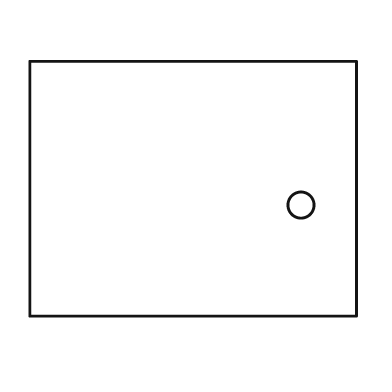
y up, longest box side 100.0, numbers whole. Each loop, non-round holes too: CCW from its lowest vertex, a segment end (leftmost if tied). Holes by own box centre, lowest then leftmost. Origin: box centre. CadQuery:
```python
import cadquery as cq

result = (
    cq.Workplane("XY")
    .moveTo(-50.0, -39.0)
    .lineTo(50.0, -39.0)
    .lineTo(50.0, 39.0)
    .lineTo(-50.0, 39.0)
    .close()
    .moveTo(33.0, -5.0)
    .circle(4.0)
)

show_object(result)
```